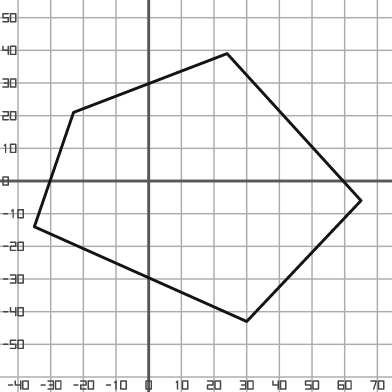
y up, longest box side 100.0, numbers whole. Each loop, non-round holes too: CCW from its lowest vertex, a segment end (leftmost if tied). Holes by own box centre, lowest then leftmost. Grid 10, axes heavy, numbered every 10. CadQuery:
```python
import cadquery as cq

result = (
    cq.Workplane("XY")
    .moveTo(30.0, -43.0)
    .lineTo(65.0, -6.0)
    .lineTo(24.0, 39.0)
    .lineTo(-23.0, 21.0)
    .lineTo(-35.0, -14.0)
    .close()
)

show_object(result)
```